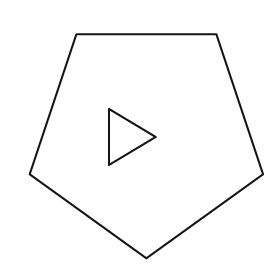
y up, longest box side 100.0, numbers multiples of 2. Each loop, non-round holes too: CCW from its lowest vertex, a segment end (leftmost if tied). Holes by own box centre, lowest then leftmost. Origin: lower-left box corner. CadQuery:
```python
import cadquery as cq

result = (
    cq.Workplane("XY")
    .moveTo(50.0, 0.0)
    .lineTo(100.0, 36.0)
    .lineTo(80.0, 96.0)
    .lineTo(20.0, 96.0)
    .lineTo(0.0, 36.0)
    .close()
    .moveTo(34.0, 40.0)
    .lineTo(54.0, 52.0)
    .lineTo(34.0, 64.0)
    .close()
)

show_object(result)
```